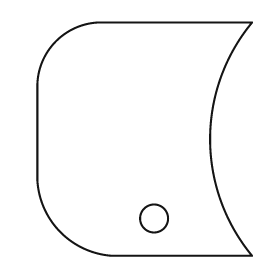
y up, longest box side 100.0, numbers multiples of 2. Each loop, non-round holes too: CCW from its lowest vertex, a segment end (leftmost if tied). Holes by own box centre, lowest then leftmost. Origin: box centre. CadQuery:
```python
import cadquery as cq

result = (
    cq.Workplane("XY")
    .moveTo(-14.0, -50.0)
    .lineTo(46.0, -50.0)
    .threePointArc((28.0, 0.0), (46.0, 50.0))
    .lineTo(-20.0, 50.0)
    .threePointArc((-38.0, 42.0), (-46.0, 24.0))
    .lineTo(-46.0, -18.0)
    .threePointArc((-36.0, -40.0), (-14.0, -50.0))
    .close()
    .moveTo(4.0, -34.0)
    .circle(6.0)
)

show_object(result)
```